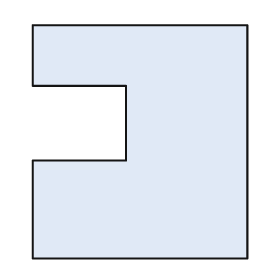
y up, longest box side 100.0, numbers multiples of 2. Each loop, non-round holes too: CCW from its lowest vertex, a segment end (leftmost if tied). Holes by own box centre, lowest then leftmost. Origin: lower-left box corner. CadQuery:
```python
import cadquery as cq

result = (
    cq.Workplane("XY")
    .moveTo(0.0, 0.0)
    .lineTo(92.0, 0.0)
    .lineTo(92.0, 100.0)
    .lineTo(0.0, 100.0)
    .lineTo(0.0, 74.0)
    .lineTo(40.0, 74.0)
    .lineTo(40.0, 42.0)
    .lineTo(0.0, 42.0)
    .close()
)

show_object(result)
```